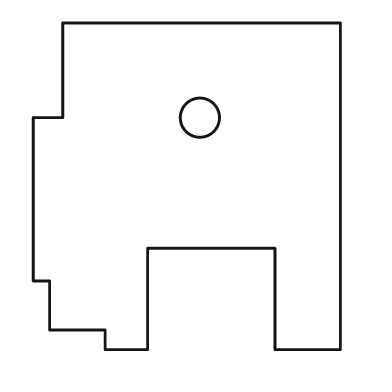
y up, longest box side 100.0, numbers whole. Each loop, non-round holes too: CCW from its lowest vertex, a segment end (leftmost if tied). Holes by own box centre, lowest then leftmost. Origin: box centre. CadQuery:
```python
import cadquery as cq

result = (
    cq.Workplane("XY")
    .moveTo(-25.0, -50.0)
    .lineTo(-12.0, -50.0)
    .lineTo(-12.0, -19.0)
    .lineTo(27.0, -19.0)
    .lineTo(27.0, -50.0)
    .lineTo(47.0, -50.0)
    .lineTo(47.0, 50.0)
    .lineTo(-38.0, 50.0)
    .lineTo(-38.0, 21.0)
    .lineTo(-47.0, 21.0)
    .lineTo(-47.0, -29.0)
    .lineTo(-42.0, -29.0)
    .lineTo(-42.0, -44.0)
    .lineTo(-25.0, -44.0)
    .close()
    .moveTo(4.0, 21.0)
    .circle(6.0)
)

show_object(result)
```